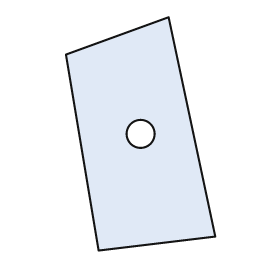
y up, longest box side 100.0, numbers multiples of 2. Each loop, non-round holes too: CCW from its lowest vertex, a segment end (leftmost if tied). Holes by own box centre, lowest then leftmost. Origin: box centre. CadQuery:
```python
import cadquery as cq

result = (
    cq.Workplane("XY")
    .moveTo(-18.0, -50.0)
    .lineTo(32.0, -44.0)
    .lineTo(12.0, 50.0)
    .lineTo(-32.0, 34.0)
    .close()
    .moveTo(0.0, 0.0)
    .circle(6.0)
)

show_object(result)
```